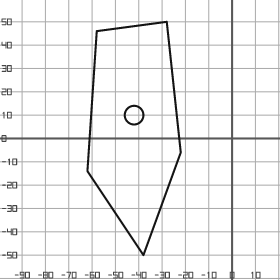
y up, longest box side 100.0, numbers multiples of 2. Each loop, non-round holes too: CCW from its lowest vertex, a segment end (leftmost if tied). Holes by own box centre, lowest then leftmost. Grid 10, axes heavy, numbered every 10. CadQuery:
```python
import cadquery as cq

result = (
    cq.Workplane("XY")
    .moveTo(-38.0, -50.0)
    .lineTo(-22.0, -6.0)
    .lineTo(-28.0, 50.0)
    .lineTo(-58.0, 46.0)
    .lineTo(-62.0, -14.0)
    .close()
    .moveTo(-42.0, 10.0)
    .circle(4.0)
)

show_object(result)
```